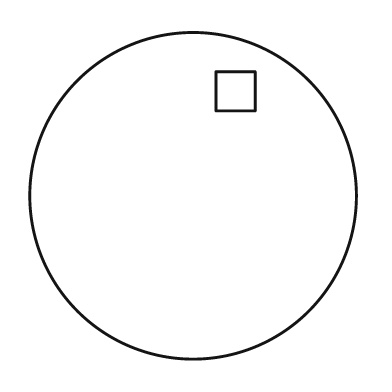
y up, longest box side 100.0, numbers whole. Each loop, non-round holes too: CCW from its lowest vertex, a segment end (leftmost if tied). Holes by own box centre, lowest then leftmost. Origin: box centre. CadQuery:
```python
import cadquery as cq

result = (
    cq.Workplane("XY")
    .moveTo(0.0, 0.0)
    .circle(50.0)
    .moveTo(7.0, 26.0)
    .lineTo(19.0, 26.0)
    .lineTo(19.0, 38.0)
    .lineTo(7.0, 38.0)
    .close()
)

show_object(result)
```